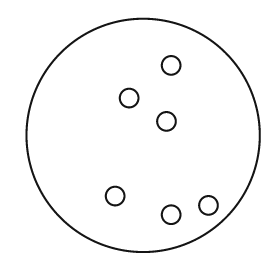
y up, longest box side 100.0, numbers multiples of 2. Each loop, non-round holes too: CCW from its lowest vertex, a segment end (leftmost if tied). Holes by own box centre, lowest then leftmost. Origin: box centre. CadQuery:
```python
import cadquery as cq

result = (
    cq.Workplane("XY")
    .moveTo(0.0, 0.0)
    .circle(50.0)
    .moveTo(12.0, -34.0)
    .circle(4.0)
    .moveTo(28.0, -30.0)
    .circle(4.0)
    .moveTo(-12.0, -26.0)
    .circle(4.0)
    .moveTo(10.0, 6.0)
    .circle(4.0)
    .moveTo(-6.0, 16.0)
    .circle(4.0)
    .moveTo(12.0, 30.0)
    .circle(4.0)
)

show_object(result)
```